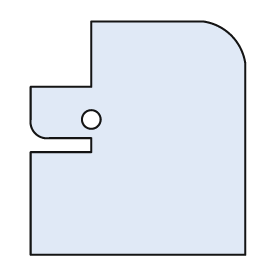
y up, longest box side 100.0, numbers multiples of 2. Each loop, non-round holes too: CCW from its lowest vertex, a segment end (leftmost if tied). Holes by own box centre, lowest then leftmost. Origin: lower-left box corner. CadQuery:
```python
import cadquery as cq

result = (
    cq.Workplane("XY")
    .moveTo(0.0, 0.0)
    .lineTo(92.0, 0.0)
    .lineTo(92.0, 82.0)
    .threePointArc((86.0, 94.0), (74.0, 100.0))
    .lineTo(26.0, 100.0)
    .lineTo(26.0, 72.0)
    .lineTo(0.0, 72.0)
    .lineTo(0.0, 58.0)
    .threePointArc((2.0, 52.0), (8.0, 50.0))
    .lineTo(26.0, 50.0)
    .lineTo(26.0, 44.0)
    .lineTo(0.0, 44.0)
    .close()
    .moveTo(26.0, 58.0)
    .circle(4.0)
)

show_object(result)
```